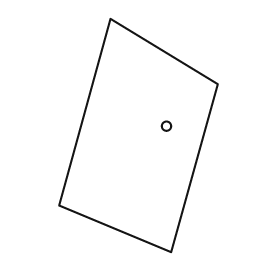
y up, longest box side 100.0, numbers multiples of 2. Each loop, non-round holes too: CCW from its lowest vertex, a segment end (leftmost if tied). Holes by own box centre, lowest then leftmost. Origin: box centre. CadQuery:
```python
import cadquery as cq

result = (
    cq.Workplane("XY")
    .moveTo(14.0, -50.0)
    .lineTo(34.0, 22.0)
    .lineTo(-12.0, 50.0)
    .lineTo(-34.0, -30.0)
    .close()
    .moveTo(12.0, 4.0)
    .circle(2.0)
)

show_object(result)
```